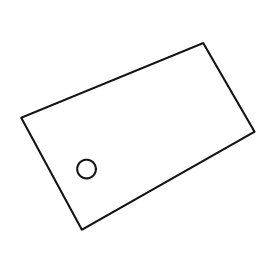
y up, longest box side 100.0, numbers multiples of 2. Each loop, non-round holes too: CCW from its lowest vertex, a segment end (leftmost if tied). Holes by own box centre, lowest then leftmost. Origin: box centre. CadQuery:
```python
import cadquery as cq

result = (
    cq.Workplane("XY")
    .moveTo(-24.0, -40.0)
    .lineTo(50.0, 2.0)
    .lineTo(28.0, 40.0)
    .lineTo(-50.0, 8.0)
    .close()
    .moveTo(-22.0, -14.0)
    .circle(4.0)
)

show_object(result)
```